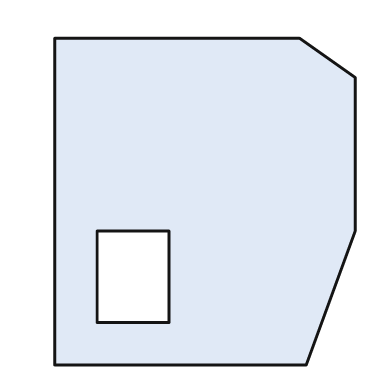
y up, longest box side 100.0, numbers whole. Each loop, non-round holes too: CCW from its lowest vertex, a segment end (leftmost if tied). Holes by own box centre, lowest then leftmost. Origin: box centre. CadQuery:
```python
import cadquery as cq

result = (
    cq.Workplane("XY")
    .moveTo(-46.0, -50.0)
    .lineTo(31.0, -50.0)
    .lineTo(46.0, -9.0)
    .lineTo(46.0, 38.0)
    .lineTo(29.0, 50.0)
    .lineTo(-46.0, 50.0)
    .close()
    .moveTo(-33.0, -37.0)
    .lineTo(-11.0, -37.0)
    .lineTo(-11.0, -9.0)
    .lineTo(-33.0, -9.0)
    .close()
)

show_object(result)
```